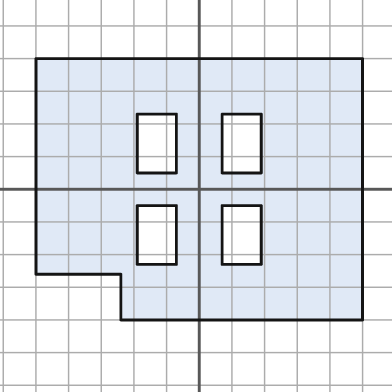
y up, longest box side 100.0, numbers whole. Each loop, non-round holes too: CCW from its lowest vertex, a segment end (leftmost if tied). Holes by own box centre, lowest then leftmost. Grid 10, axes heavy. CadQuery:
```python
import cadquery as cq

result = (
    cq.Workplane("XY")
    .moveTo(-24.0, -40.0)
    .lineTo(50.0, -40.0)
    .lineTo(50.0, 40.0)
    .lineTo(-50.0, 40.0)
    .lineTo(-50.0, -26.0)
    .lineTo(-24.0, -26.0)
    .close()
    .moveTo(-19.0, -23.0)
    .lineTo(-7.0, -23.0)
    .lineTo(-7.0, -5.0)
    .lineTo(-19.0, -5.0)
    .close()
    .moveTo(7.0, -23.0)
    .lineTo(19.0, -23.0)
    .lineTo(19.0, -5.0)
    .lineTo(7.0, -5.0)
    .close()
    .moveTo(-19.0, 5.0)
    .lineTo(-7.0, 5.0)
    .lineTo(-7.0, 23.0)
    .lineTo(-19.0, 23.0)
    .close()
    .moveTo(7.0, 5.0)
    .lineTo(19.0, 5.0)
    .lineTo(19.0, 23.0)
    .lineTo(7.0, 23.0)
    .close()
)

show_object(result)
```